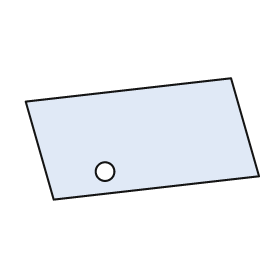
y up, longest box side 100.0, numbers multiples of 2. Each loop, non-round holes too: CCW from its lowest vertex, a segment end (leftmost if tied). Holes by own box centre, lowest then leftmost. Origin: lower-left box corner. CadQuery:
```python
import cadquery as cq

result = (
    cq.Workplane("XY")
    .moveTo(12.0, 0.0)
    .lineTo(100.0, 10.0)
    .lineTo(88.0, 52.0)
    .lineTo(0.0, 42.0)
    .close()
    .moveTo(34.0, 12.0)
    .circle(4.0)
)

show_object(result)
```